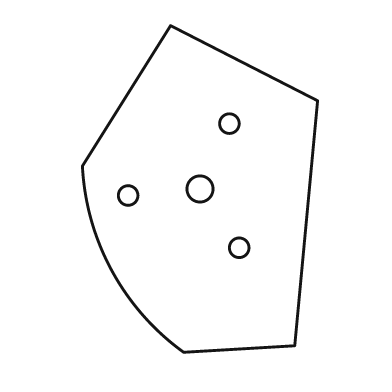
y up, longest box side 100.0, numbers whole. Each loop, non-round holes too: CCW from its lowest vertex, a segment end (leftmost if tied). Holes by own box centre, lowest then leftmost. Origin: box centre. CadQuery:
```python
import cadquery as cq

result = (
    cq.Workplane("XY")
    .moveTo(-5.0, -50.0)
    .lineTo(29.0, -48.0)
    .lineTo(36.0, 27.0)
    .lineTo(-9.0, 50.0)
    .lineTo(-36.0, 7.0)
    .threePointArc((-27.0, -25.0), (-5.0, -50.0))
    .close()
    .moveTo(12.0, -18.0)
    .circle(3.0)
    .moveTo(-22.0, -2.0)
    .circle(3.0)
    .moveTo(0.0, 0.0)
    .circle(4.0)
    .moveTo(9.0, 20.0)
    .circle(3.0)
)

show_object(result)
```